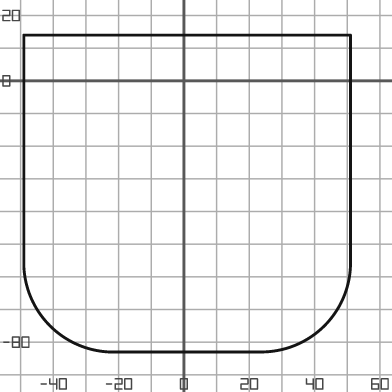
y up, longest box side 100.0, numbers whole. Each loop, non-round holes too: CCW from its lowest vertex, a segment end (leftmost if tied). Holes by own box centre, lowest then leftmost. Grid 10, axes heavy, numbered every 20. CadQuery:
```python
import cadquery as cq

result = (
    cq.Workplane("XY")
    .moveTo(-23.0, -83.0)
    .lineTo(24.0, -83.0)
    .threePointArc((43.0, -75.0), (51.0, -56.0))
    .lineTo(51.0, 14.0)
    .lineTo(-49.0, 14.0)
    .lineTo(-49.0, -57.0)
    .threePointArc((-41.0, -75.0), (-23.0, -83.0))
    .close()
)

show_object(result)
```